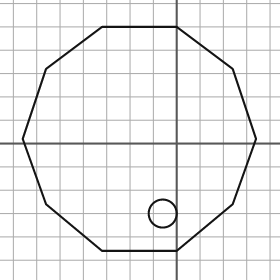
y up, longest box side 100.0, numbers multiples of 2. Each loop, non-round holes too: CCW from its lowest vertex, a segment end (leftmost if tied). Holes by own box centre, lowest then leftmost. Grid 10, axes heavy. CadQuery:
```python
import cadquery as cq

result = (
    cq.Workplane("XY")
    .moveTo(-32.0, -46.0)
    .lineTo(0.0, -46.0)
    .lineTo(24.0, -26.0)
    .lineTo(34.0, 2.0)
    .lineTo(24.0, 32.0)
    .lineTo(0.0, 50.0)
    .lineTo(-32.0, 50.0)
    .lineTo(-56.0, 32.0)
    .lineTo(-66.0, 2.0)
    .lineTo(-56.0, -26.0)
    .close()
    .moveTo(-6.0, -30.0)
    .circle(6.0)
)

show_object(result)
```